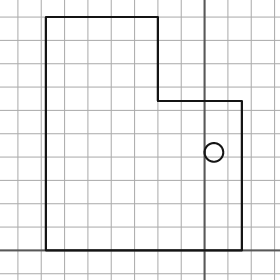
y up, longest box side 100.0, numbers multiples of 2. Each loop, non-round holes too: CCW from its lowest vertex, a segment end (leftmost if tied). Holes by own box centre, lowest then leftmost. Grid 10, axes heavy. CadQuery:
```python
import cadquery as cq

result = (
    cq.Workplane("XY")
    .moveTo(-68.0, 0.0)
    .lineTo(16.0, 0.0)
    .lineTo(16.0, 64.0)
    .lineTo(-20.0, 64.0)
    .lineTo(-20.0, 100.0)
    .lineTo(-68.0, 100.0)
    .close()
    .moveTo(4.0, 42.0)
    .circle(4.0)
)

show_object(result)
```